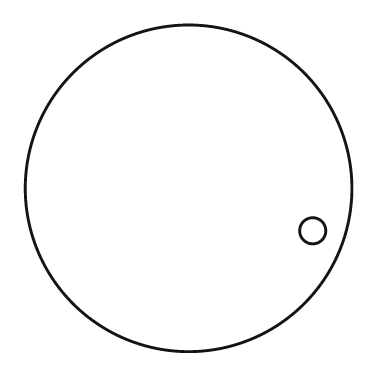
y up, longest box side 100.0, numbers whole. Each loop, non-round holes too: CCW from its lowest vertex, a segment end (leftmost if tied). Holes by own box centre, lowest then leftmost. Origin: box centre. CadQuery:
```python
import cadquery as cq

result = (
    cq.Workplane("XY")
    .moveTo(0.0, 0.0)
    .circle(50.0)
    .moveTo(38.0, -13.0)
    .circle(4.0)
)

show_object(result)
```